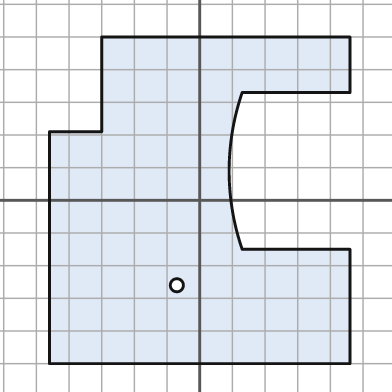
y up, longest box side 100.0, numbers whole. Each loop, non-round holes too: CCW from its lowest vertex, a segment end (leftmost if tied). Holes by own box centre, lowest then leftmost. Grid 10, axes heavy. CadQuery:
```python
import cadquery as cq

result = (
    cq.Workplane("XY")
    .moveTo(-46.0, -50.0)
    .lineTo(46.0, -50.0)
    .lineTo(46.0, -15.0)
    .lineTo(13.0, -15.0)
    .threePointArc((9.0, 9.0), (13.0, 33.0))
    .lineTo(46.0, 33.0)
    .lineTo(46.0, 50.0)
    .lineTo(-30.0, 50.0)
    .lineTo(-30.0, 21.0)
    .lineTo(-46.0, 21.0)
    .close()
    .moveTo(-7.0, -26.0)
    .circle(2.0)
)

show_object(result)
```